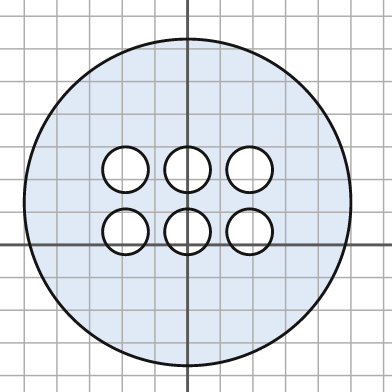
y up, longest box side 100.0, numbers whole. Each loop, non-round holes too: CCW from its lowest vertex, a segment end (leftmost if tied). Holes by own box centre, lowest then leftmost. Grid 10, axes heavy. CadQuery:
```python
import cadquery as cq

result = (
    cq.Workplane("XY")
    .moveTo(0.0, 13.0)
    .circle(50.0)
    .moveTo(-19.0, 4.0)
    .circle(7.0)
    .moveTo(0.0, 4.0)
    .circle(7.0)
    .moveTo(19.0, 4.0)
    .circle(7.0)
    .moveTo(-19.0, 23.0)
    .circle(7.0)
    .moveTo(0.0, 23.0)
    .circle(7.0)
    .moveTo(19.0, 23.0)
    .circle(7.0)
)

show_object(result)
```